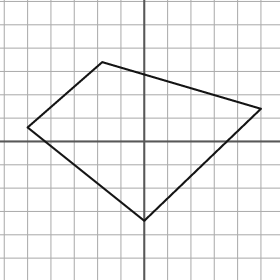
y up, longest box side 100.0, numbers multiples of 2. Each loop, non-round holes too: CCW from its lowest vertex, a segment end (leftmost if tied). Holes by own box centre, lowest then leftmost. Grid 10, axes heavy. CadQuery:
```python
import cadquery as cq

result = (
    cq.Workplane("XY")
    .moveTo(0.0, -34.0)
    .lineTo(50.0, 14.0)
    .lineTo(-18.0, 34.0)
    .lineTo(-50.0, 6.0)
    .close()
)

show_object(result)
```